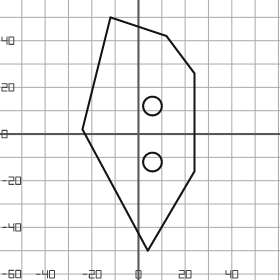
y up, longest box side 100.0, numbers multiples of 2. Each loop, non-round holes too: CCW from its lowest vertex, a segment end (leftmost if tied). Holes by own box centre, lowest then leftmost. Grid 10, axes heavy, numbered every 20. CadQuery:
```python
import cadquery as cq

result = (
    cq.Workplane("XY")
    .moveTo(4.0, -50.0)
    .lineTo(24.0, -16.0)
    .lineTo(24.0, 26.0)
    .lineTo(12.0, 42.0)
    .lineTo(-12.0, 50.0)
    .lineTo(-24.0, 2.0)
    .close()
    .moveTo(6.0, -12.0)
    .circle(4.0)
    .moveTo(6.0, 12.0)
    .circle(4.0)
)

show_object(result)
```